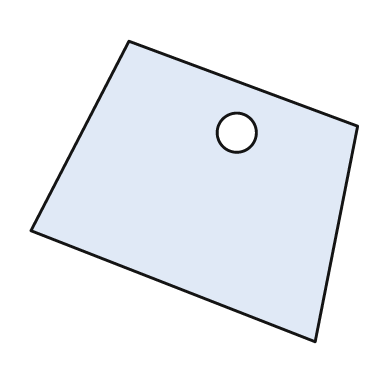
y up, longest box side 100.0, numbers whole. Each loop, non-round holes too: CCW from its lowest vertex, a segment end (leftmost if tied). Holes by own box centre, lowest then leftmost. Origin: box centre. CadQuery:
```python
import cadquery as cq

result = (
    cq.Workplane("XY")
    .moveTo(37.0, -46.0)
    .lineTo(50.0, 20.0)
    .lineTo(-20.0, 46.0)
    .lineTo(-50.0, -12.0)
    .close()
    .moveTo(13.0, 18.0)
    .circle(6.0)
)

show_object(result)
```